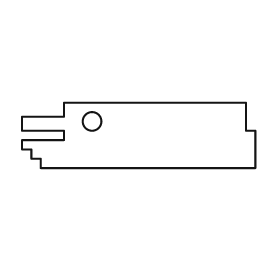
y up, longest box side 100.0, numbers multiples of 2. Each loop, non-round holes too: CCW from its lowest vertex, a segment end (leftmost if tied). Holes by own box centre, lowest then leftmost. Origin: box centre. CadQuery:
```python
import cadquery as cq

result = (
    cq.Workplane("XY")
    .moveTo(-42.0, -14.0)
    .lineTo(50.0, -14.0)
    .lineTo(50.0, 2.0)
    .lineTo(46.0, 2.0)
    .lineTo(46.0, 14.0)
    .lineTo(-32.0, 14.0)
    .lineTo(-32.0, 8.0)
    .lineTo(-50.0, 8.0)
    .lineTo(-50.0, 2.0)
    .lineTo(-32.0, 2.0)
    .lineTo(-32.0, -2.0)
    .lineTo(-50.0, -2.0)
    .lineTo(-50.0, -6.0)
    .lineTo(-46.0, -6.0)
    .lineTo(-46.0, -10.0)
    .lineTo(-42.0, -10.0)
    .close()
    .moveTo(-20.0, 6.0)
    .circle(4.0)
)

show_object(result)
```